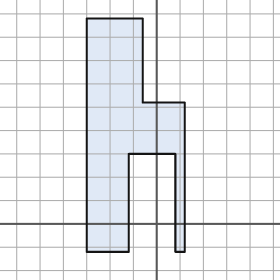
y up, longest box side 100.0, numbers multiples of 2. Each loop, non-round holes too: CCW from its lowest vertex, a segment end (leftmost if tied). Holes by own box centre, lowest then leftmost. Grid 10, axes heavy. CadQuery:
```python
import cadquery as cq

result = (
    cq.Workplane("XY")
    .moveTo(-30.0, -12.0)
    .lineTo(-12.0, -12.0)
    .lineTo(-12.0, 30.0)
    .lineTo(8.0, 30.0)
    .lineTo(8.0, -12.0)
    .lineTo(12.0, -12.0)
    .lineTo(12.0, 52.0)
    .lineTo(-6.0, 52.0)
    .lineTo(-6.0, 88.0)
    .lineTo(-30.0, 88.0)
    .close()
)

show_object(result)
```